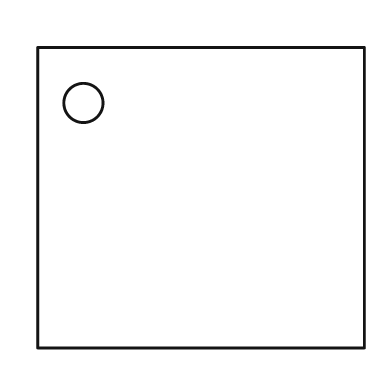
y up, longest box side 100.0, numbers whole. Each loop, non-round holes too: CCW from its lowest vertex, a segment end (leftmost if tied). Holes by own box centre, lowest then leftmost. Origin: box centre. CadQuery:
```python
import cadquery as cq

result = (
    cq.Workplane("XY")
    .moveTo(-50.0, -46.0)
    .lineTo(50.0, -46.0)
    .lineTo(50.0, 46.0)
    .lineTo(-50.0, 46.0)
    .close()
    .moveTo(-36.0, 29.0)
    .circle(6.0)
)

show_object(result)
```